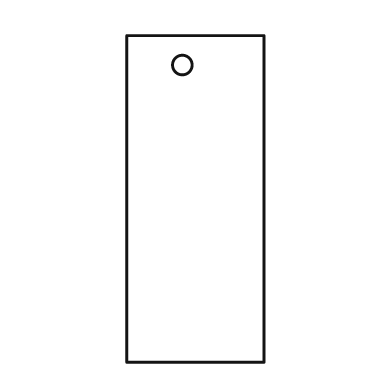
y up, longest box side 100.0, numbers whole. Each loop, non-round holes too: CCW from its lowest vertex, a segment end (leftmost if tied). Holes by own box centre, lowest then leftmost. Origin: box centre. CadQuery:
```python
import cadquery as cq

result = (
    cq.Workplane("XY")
    .moveTo(-21.0, -50.0)
    .lineTo(21.0, -50.0)
    .lineTo(21.0, 50.0)
    .lineTo(-21.0, 50.0)
    .close()
    .moveTo(-4.0, 41.0)
    .circle(3.0)
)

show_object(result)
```